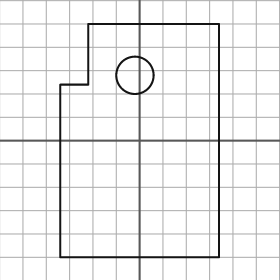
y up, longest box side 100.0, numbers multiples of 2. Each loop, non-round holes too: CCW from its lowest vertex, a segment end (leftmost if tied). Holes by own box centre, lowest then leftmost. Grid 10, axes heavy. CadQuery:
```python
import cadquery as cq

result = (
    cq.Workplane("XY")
    .moveTo(-34.0, -50.0)
    .lineTo(34.0, -50.0)
    .lineTo(34.0, 50.0)
    .lineTo(-22.0, 50.0)
    .lineTo(-22.0, 24.0)
    .lineTo(-34.0, 24.0)
    .close()
    .moveTo(-2.0, 28.0)
    .circle(8.0)
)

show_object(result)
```